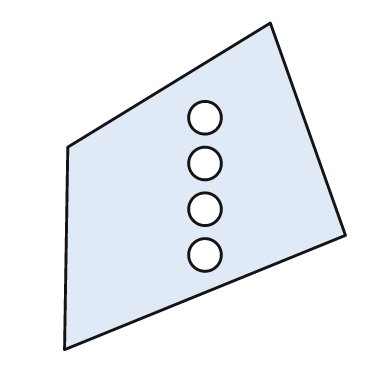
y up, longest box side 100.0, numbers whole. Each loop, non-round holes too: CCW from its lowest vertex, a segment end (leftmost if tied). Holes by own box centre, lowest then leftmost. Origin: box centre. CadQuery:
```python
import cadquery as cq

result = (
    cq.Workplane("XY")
    .moveTo(-43.0, -50.0)
    .lineTo(43.0, -15.0)
    .lineTo(20.0, 50.0)
    .lineTo(-42.0, 12.0)
    .close()
    .moveTo(0.0, -21.0)
    .circle(5.0)
    .moveTo(0.0, -7.0)
    .circle(5.0)
    .moveTo(0.0, 7.0)
    .circle(5.0)
    .moveTo(0.0, 21.0)
    .circle(5.0)
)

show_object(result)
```